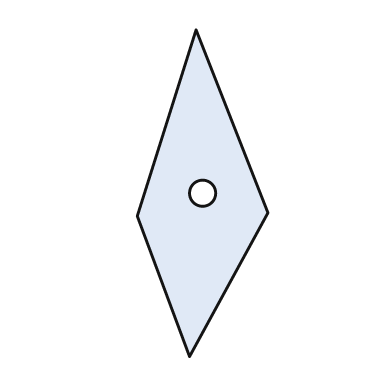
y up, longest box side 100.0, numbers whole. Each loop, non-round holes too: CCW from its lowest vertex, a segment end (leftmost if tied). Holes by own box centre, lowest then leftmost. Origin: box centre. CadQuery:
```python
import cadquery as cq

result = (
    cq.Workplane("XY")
    .moveTo(-4.0, -50.0)
    .lineTo(20.0, -6.0)
    .lineTo(-2.0, 50.0)
    .lineTo(-20.0, -7.0)
    .close()
    .moveTo(0.0, 0.0)
    .circle(4.0)
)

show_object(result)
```